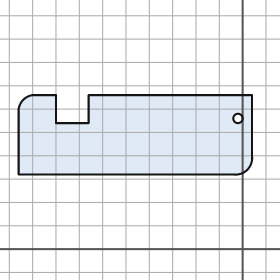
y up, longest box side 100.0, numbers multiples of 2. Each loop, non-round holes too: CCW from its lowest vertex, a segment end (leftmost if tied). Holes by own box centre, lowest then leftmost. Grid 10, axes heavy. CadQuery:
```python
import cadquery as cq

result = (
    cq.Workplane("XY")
    .moveTo(-96.0, 32.0)
    .lineTo(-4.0, 32.0)
    .threePointArc((2.0, 34.0), (4.0, 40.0))
    .lineTo(4.0, 66.0)
    .lineTo(-66.0, 66.0)
    .lineTo(-66.0, 54.0)
    .lineTo(-80.0, 54.0)
    .lineTo(-80.0, 66.0)
    .lineTo(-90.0, 66.0)
    .threePointArc((-94.0, 64.0), (-96.0, 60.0))
    .close()
    .moveTo(-2.0, 56.0)
    .circle(2.0)
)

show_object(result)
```